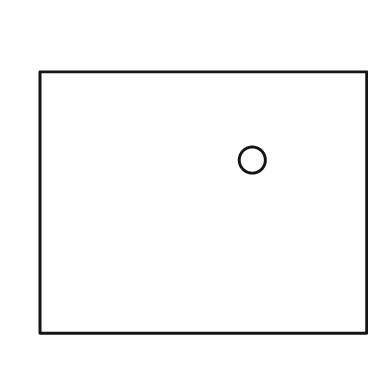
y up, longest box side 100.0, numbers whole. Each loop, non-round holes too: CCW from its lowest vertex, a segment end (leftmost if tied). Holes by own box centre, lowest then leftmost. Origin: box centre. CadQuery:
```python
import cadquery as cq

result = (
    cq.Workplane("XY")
    .moveTo(-50.0, -40.0)
    .lineTo(50.0, -40.0)
    .lineTo(50.0, 40.0)
    .lineTo(-50.0, 40.0)
    .close()
    .moveTo(15.0, 13.0)
    .circle(4.0)
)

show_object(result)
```